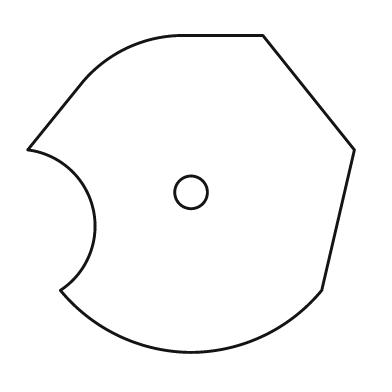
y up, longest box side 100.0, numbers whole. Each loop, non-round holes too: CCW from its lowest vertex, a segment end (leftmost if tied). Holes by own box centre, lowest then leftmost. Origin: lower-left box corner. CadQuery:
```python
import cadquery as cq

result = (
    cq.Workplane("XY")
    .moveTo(50.0, 0.0)
    .threePointArc((72.0, 5.0), (90.0, 19.0))
    .lineTo(100.0, 62.0)
    .lineTo(72.0, 97.0)
    .lineTo(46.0, 97.0)
    .threePointArc((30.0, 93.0), (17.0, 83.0))
    .lineTo(0.0, 62.0)
    .threePointArc((20.0, 44.0), (10.0, 19.0))
    .threePointArc((28.0, 5.0), (50.0, 0.0))
    .close()
    .moveTo(50.0, 49.0)
    .circle(5.0)
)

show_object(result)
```